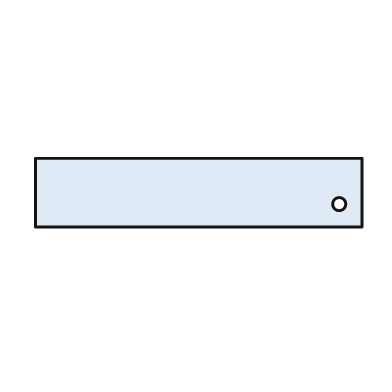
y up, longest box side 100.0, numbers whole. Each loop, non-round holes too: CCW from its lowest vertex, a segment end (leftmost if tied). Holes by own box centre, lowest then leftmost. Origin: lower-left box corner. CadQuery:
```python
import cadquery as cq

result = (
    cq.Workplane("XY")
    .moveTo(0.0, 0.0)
    .lineTo(100.0, 0.0)
    .lineTo(100.0, 21.0)
    .lineTo(0.0, 21.0)
    .close()
    .moveTo(93.0, 7.0)
    .circle(2.0)
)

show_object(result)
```